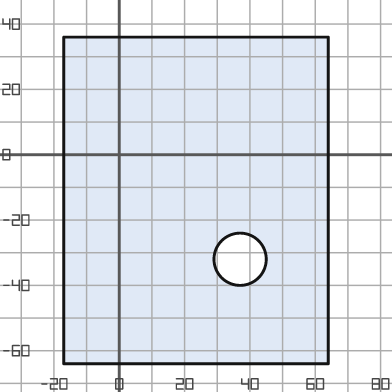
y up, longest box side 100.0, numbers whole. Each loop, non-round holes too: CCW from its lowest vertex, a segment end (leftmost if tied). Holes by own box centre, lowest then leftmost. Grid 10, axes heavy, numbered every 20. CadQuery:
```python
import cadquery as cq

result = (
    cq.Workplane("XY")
    .moveTo(-17.0, -64.0)
    .lineTo(64.0, -64.0)
    .lineTo(64.0, 36.0)
    .lineTo(-17.0, 36.0)
    .close()
    .moveTo(37.0, -32.0)
    .circle(8.0)
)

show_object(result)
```